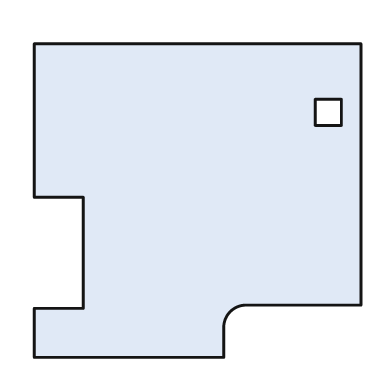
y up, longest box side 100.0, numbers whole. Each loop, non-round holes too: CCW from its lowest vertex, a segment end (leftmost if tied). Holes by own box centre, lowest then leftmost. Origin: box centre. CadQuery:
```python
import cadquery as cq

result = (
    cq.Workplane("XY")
    .moveTo(-50.0, -48.0)
    .lineTo(8.0, -48.0)
    .lineTo(8.0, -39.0)
    .threePointArc((10.0, -34.0), (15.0, -32.0))
    .lineTo(50.0, -32.0)
    .lineTo(50.0, 48.0)
    .lineTo(-50.0, 48.0)
    .lineTo(-50.0, 1.0)
    .lineTo(-35.0, 1.0)
    .lineTo(-35.0, -33.0)
    .lineTo(-50.0, -33.0)
    .close()
    .moveTo(36.0, 23.0)
    .lineTo(44.0, 23.0)
    .lineTo(44.0, 31.0)
    .lineTo(36.0, 31.0)
    .close()
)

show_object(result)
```